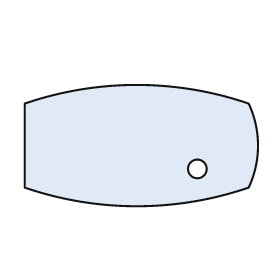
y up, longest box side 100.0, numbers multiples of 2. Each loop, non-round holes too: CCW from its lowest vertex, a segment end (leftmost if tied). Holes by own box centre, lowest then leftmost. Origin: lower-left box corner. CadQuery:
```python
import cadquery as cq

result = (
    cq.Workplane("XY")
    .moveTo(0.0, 8.0)
    .threePointArc((48.0, 0.0), (96.0, 8.0))
    .threePointArc((100.0, 26.0), (96.0, 44.0))
    .threePointArc((48.0, 52.0), (0.0, 44.0))
    .close()
    .moveTo(74.0, 16.0)
    .circle(4.0)
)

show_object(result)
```